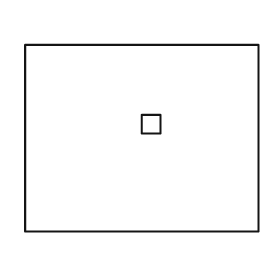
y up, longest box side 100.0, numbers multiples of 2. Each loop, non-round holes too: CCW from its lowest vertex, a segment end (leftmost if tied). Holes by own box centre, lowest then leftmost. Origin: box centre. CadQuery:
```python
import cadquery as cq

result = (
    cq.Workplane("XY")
    .moveTo(-50.0, -40.0)
    .lineTo(50.0, -40.0)
    .lineTo(50.0, 40.0)
    .lineTo(-50.0, 40.0)
    .close()
    .moveTo(0.0, 2.0)
    .lineTo(8.0, 2.0)
    .lineTo(8.0, 10.0)
    .lineTo(0.0, 10.0)
    .close()
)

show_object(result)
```